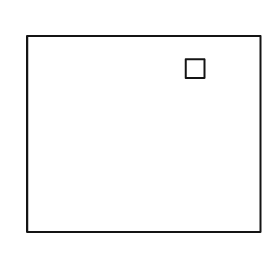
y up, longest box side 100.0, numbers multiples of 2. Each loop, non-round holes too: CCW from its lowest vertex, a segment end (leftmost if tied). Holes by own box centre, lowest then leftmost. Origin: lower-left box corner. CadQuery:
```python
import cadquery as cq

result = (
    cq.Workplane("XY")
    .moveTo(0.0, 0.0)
    .lineTo(100.0, 0.0)
    .lineTo(100.0, 84.0)
    .lineTo(0.0, 84.0)
    .close()
    .moveTo(68.0, 66.0)
    .lineTo(76.0, 66.0)
    .lineTo(76.0, 74.0)
    .lineTo(68.0, 74.0)
    .close()
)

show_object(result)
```